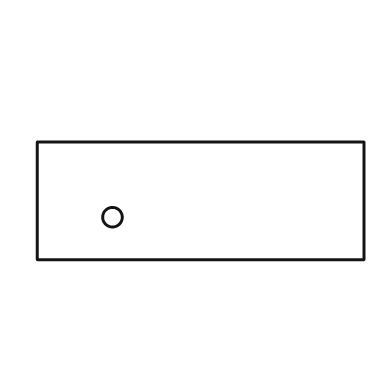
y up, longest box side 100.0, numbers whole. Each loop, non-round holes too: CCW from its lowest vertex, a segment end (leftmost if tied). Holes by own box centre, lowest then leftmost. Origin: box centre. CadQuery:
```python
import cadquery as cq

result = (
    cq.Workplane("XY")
    .moveTo(-50.0, -18.0)
    .lineTo(50.0, -18.0)
    .lineTo(50.0, 18.0)
    .lineTo(-50.0, 18.0)
    .close()
    .moveTo(-27.0, -5.0)
    .circle(3.0)
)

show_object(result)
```